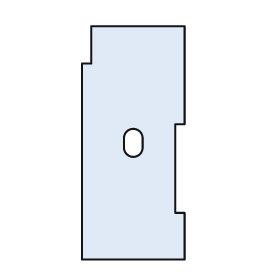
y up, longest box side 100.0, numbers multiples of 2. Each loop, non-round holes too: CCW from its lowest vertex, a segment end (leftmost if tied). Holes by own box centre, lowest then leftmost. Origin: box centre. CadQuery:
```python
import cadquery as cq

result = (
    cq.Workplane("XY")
    .moveTo(-22.0, -50.0)
    .lineTo(22.0, -50.0)
    .lineTo(22.0, -30.0)
    .lineTo(18.0, -30.0)
    .lineTo(18.0, 8.0)
    .lineTo(22.0, 8.0)
    .lineTo(22.0, 50.0)
    .lineTo(-18.0, 50.0)
    .lineTo(-18.0, 34.0)
    .lineTo(-22.0, 34.0)
    .close()
    .moveTo(-4.0, -2.0)
    .threePointArc((0.0, -6.0), (4.0, -2.0))
    .lineTo(4.0, 2.0)
    .threePointArc((0.0, 6.0), (-4.0, 2.0))
    .close()
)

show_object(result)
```